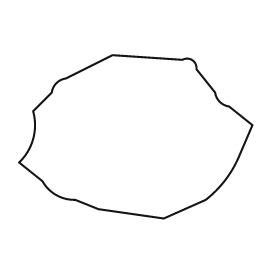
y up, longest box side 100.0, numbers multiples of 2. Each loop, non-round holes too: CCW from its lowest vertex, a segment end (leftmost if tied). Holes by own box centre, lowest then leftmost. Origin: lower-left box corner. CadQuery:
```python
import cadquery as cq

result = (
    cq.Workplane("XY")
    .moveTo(62.0, 0.0)
    .lineTo(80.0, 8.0)
    .threePointArc((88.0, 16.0), (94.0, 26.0))
    .lineTo(100.0, 40.0)
    .lineTo(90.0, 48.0)
    .threePointArc((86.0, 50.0), (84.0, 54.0))
    .lineTo(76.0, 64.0)
    .threePointArc((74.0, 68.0), (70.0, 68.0))
    .lineTo(40.0, 70.0)
    .lineTo(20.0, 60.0)
    .threePointArc((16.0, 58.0), (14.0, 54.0))
    .lineTo(6.0, 46.0)
    .threePointArc((6.0, 34.0), (0.0, 24.0))
    .lineTo(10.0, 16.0)
    .threePointArc((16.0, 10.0), (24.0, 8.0))
    .lineTo(34.0, 4.0)
    .close()
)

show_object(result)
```